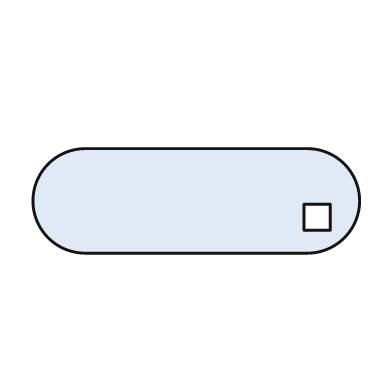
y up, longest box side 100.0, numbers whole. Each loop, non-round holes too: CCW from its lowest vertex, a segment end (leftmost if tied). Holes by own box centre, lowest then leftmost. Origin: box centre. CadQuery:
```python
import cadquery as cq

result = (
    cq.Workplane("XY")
    .moveTo(-34.0, -16.0)
    .lineTo(34.0, -16.0)
    .threePointArc((50.0, 0.0), (34.0, 16.0))
    .lineTo(-34.0, 16.0)
    .threePointArc((-50.0, 0.0), (-34.0, -16.0))
    .close()
    .moveTo(33.0, -9.0)
    .lineTo(41.0, -9.0)
    .lineTo(41.0, -1.0)
    .lineTo(33.0, -1.0)
    .close()
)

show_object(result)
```